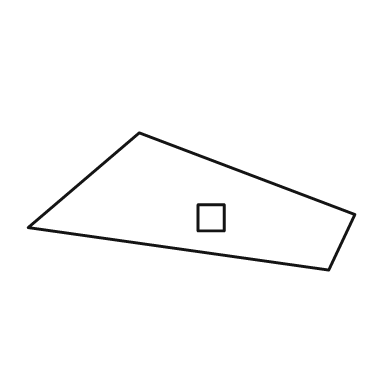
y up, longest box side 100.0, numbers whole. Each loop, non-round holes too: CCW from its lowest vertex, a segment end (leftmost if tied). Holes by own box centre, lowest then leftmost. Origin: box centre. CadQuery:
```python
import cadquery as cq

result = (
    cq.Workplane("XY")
    .moveTo(42.0, -21.0)
    .lineTo(50.0, -4.0)
    .lineTo(-16.0, 21.0)
    .lineTo(-50.0, -8.0)
    .close()
    .moveTo(2.0, -9.0)
    .lineTo(10.0, -9.0)
    .lineTo(10.0, -1.0)
    .lineTo(2.0, -1.0)
    .close()
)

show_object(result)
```